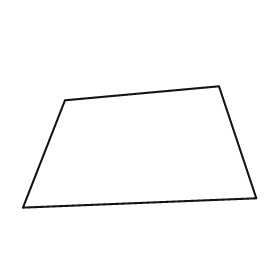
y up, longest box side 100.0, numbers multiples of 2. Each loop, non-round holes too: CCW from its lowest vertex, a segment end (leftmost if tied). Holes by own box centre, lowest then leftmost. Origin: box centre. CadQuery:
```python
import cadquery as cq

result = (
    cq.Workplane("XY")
    .moveTo(-50.0, -26.0)
    .lineTo(50.0, -22.0)
    .lineTo(34.0, 26.0)
    .lineTo(-32.0, 20.0)
    .close()
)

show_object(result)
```